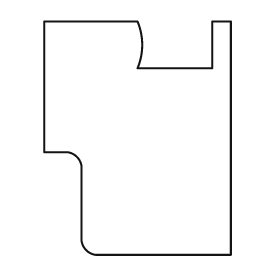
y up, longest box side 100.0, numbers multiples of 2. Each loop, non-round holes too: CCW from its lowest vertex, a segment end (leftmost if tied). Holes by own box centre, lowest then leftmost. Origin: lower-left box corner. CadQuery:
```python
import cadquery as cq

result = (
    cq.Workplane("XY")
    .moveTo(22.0, 0.0)
    .lineTo(80.0, 0.0)
    .lineTo(80.0, 100.0)
    .lineTo(72.0, 100.0)
    .lineTo(72.0, 80.0)
    .lineTo(40.0, 80.0)
    .threePointArc((42.0, 90.0), (40.0, 100.0))
    .lineTo(0.0, 100.0)
    .lineTo(0.0, 44.0)
    .lineTo(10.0, 44.0)
    .threePointArc((14.0, 42.0), (16.0, 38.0))
    .lineTo(16.0, 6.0)
    .threePointArc((18.0, 2.0), (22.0, 0.0))
    .close()
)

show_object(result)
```